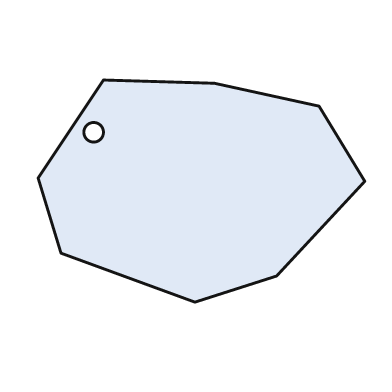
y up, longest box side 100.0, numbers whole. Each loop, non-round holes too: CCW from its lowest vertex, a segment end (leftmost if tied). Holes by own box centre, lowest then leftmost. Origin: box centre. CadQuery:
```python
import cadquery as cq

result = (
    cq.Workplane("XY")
    .moveTo(-2.0, -34.0)
    .lineTo(23.0, -26.0)
    .lineTo(50.0, 3.0)
    .lineTo(36.0, 26.0)
    .lineTo(4.0, 33.0)
    .lineTo(-30.0, 34.0)
    .lineTo(-50.0, 4.0)
    .lineTo(-43.0, -19.0)
    .close()
    .moveTo(-33.0, 18.0)
    .circle(3.0)
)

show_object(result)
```